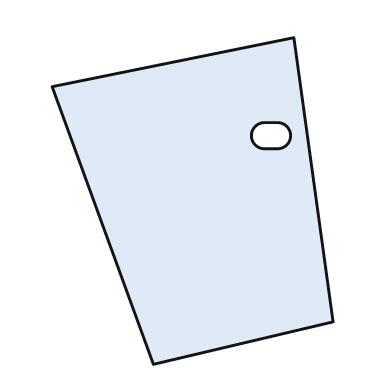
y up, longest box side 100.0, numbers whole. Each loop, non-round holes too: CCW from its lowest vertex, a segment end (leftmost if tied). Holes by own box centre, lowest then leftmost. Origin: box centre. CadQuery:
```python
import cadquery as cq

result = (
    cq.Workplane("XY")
    .moveTo(-12.0, -50.0)
    .lineTo(43.0, -37.0)
    .lineTo(31.0, 50.0)
    .lineTo(-43.0, 35.0)
    .close()
    .moveTo(22.0, 16.0)
    .lineTo(26.0, 16.0)
    .threePointArc((30.0, 20.0), (26.0, 24.0))
    .lineTo(22.0, 24.0)
    .threePointArc((18.0, 20.0), (22.0, 16.0))
    .close()
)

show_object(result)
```